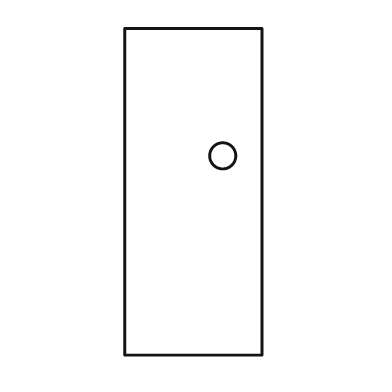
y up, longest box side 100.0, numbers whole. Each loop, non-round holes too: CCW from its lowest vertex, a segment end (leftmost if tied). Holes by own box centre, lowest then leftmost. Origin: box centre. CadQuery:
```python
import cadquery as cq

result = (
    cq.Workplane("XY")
    .moveTo(-21.0, -50.0)
    .lineTo(21.0, -50.0)
    .lineTo(21.0, 50.0)
    .lineTo(-21.0, 50.0)
    .close()
    .moveTo(9.0, 11.0)
    .circle(4.0)
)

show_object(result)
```